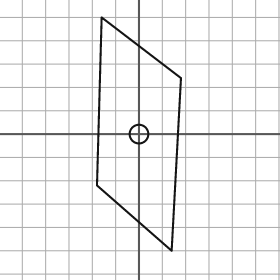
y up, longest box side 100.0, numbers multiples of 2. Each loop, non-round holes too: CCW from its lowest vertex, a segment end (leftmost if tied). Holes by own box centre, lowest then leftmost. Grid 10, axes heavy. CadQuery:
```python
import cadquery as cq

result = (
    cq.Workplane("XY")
    .moveTo(14.0, -50.0)
    .lineTo(18.0, 24.0)
    .lineTo(-16.0, 50.0)
    .lineTo(-18.0, -22.0)
    .close()
    .moveTo(0.0, 0.0)
    .circle(4.0)
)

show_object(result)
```